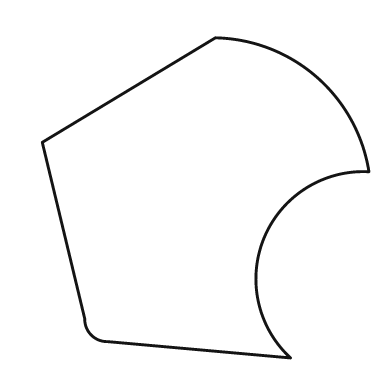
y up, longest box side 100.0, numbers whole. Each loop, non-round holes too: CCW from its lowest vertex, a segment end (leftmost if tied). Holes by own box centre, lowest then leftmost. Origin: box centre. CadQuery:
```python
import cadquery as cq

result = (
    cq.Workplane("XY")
    .moveTo(26.0, -49.0)
    .threePointArc((18.0, -12.0), (50.0, 8.0))
    .threePointArc((34.0, 37.0), (3.0, 49.0))
    .lineTo(-50.0, 17.0)
    .lineTo(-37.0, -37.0)
    .threePointArc((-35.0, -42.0), (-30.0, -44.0))
    .close()
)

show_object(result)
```